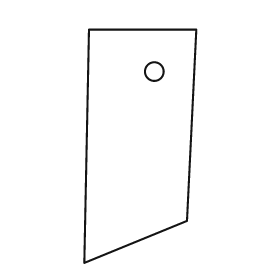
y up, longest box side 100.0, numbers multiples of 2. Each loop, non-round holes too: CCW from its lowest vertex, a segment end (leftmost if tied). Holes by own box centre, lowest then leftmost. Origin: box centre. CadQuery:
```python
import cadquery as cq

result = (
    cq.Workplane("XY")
    .moveTo(-24.0, -50.0)
    .lineTo(20.0, -32.0)
    .lineTo(24.0, 50.0)
    .lineTo(-22.0, 50.0)
    .close()
    .moveTo(6.0, 32.0)
    .circle(4.0)
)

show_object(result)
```